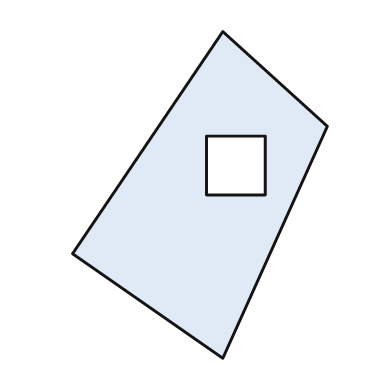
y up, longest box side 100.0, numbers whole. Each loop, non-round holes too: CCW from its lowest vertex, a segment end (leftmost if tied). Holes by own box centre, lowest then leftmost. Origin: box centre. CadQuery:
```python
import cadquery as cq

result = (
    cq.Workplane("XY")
    .moveTo(7.0, -50.0)
    .lineTo(39.0, 21.0)
    .lineTo(7.0, 50.0)
    .lineTo(-39.0, -18.0)
    .close()
    .moveTo(2.0, 0.0)
    .lineTo(20.0, 0.0)
    .lineTo(20.0, 18.0)
    .lineTo(2.0, 18.0)
    .close()
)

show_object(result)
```